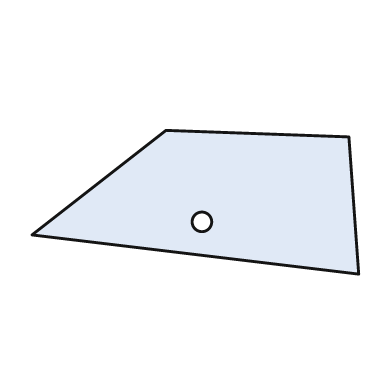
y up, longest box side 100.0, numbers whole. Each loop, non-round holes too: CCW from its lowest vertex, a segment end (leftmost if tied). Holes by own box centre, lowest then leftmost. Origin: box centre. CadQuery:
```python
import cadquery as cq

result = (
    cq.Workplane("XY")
    .moveTo(50.0, -22.0)
    .lineTo(47.0, 20.0)
    .lineTo(-9.0, 22.0)
    .lineTo(-50.0, -10.0)
    .close()
    .moveTo(2.0, -6.0)
    .circle(3.0)
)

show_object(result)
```